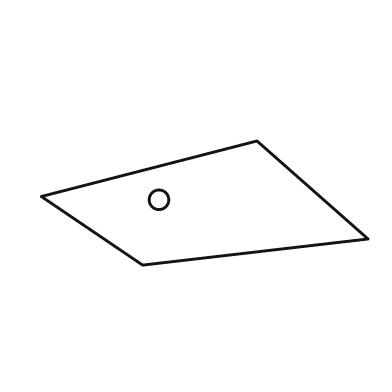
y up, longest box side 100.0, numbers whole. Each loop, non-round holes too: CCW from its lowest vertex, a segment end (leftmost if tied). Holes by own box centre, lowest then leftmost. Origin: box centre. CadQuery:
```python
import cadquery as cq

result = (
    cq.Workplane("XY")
    .moveTo(-19.0, -19.0)
    .lineTo(50.0, -11.0)
    .lineTo(16.0, 19.0)
    .lineTo(-50.0, 2.0)
    .close()
    .moveTo(-14.0, 1.0)
    .circle(3.0)
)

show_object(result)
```